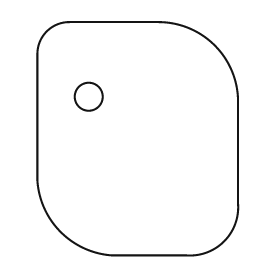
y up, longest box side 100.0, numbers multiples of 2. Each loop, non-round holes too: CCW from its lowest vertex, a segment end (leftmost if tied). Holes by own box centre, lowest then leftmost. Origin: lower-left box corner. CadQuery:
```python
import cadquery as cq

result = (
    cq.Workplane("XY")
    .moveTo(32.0, 0.0)
    .lineTo(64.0, 0.0)
    .threePointArc((80.0, 6.0), (86.0, 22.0))
    .lineTo(86.0, 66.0)
    .threePointArc((76.0, 90.0), (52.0, 100.0))
    .lineTo(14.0, 100.0)
    .threePointArc((4.0, 96.0), (0.0, 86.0))
    .lineTo(0.0, 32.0)
    .threePointArc((10.0, 10.0), (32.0, 0.0))
    .close()
    .moveTo(22.0, 68.0)
    .circle(6.0)
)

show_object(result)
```